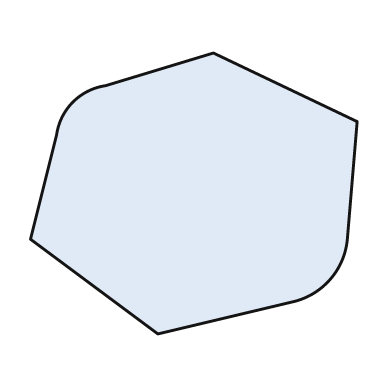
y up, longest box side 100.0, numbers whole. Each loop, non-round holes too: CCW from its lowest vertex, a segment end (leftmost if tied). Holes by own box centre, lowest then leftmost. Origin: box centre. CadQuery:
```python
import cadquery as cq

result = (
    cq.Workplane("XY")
    .moveTo(-11.0, -43.0)
    .lineTo(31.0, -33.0)
    .threePointArc((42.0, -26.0), (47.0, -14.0))
    .lineTo(50.0, 22.0)
    .lineTo(6.0, 43.0)
    .lineTo(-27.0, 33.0)
    .threePointArc((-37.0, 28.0), (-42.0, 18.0))
    .lineTo(-50.0, -14.0)
    .close()
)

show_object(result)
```